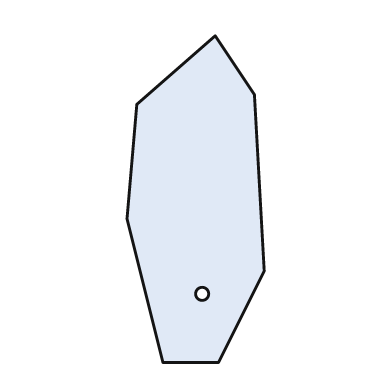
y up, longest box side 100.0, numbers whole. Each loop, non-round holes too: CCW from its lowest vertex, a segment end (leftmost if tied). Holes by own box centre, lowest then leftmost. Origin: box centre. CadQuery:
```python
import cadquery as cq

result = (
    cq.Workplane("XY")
    .moveTo(-10.0, -50.0)
    .lineTo(7.0, -50.0)
    .lineTo(21.0, -22.0)
    .lineTo(18.0, 32.0)
    .lineTo(6.0, 50.0)
    .lineTo(-18.0, 29.0)
    .lineTo(-21.0, -6.0)
    .close()
    .moveTo(2.0, -29.0)
    .circle(2.0)
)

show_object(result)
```